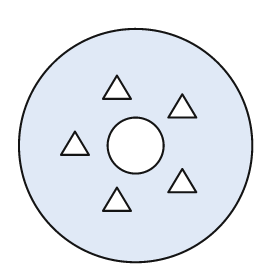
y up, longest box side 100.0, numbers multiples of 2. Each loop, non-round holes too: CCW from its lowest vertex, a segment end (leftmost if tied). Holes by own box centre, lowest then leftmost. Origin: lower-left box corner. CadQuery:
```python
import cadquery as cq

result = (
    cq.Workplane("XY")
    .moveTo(50.0, 50.0)
    .circle(50.0)
    .moveTo(36.0, 22.0)
    .lineTo(48.0, 22.0)
    .lineTo(42.0, 32.0)
    .close()
    .moveTo(64.0, 30.0)
    .lineTo(76.0, 30.0)
    .lineTo(70.0, 40.0)
    .close()
    .moveTo(50.0, 50.0)
    .circle(12.0)
    .moveTo(18.0, 46.0)
    .lineTo(30.0, 46.0)
    .lineTo(24.0, 56.0)
    .close()
    .moveTo(64.0, 62.0)
    .lineTo(76.0, 62.0)
    .lineTo(70.0, 72.0)
    .close()
    .moveTo(36.0, 70.0)
    .lineTo(48.0, 70.0)
    .lineTo(42.0, 80.0)
    .close()
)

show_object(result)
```